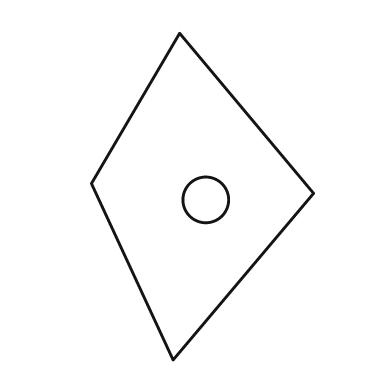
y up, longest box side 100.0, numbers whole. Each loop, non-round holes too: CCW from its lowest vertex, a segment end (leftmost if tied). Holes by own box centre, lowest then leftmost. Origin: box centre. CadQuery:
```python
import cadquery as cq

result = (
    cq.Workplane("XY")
    .moveTo(-9.0, -50.0)
    .lineTo(34.0, 1.0)
    .lineTo(-7.0, 50.0)
    .lineTo(-34.0, 4.0)
    .close()
    .moveTo(1.0, -1.0)
    .circle(7.0)
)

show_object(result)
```